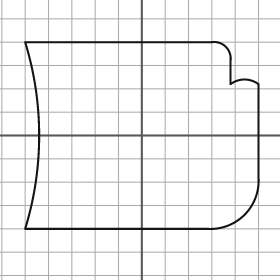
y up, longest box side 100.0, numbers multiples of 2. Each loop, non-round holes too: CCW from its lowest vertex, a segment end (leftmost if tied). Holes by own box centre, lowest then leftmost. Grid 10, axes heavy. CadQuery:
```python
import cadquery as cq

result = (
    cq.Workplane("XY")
    .moveTo(-50.0, -40.0)
    .lineTo(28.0, -40.0)
    .threePointArc((44.0, -34.0), (50.0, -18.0))
    .lineTo(50.0, 22.0)
    .threePointArc((44.0, 24.0), (38.0, 22.0))
    .lineTo(38.0, 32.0)
    .threePointArc((36.0, 38.0), (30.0, 40.0))
    .lineTo(-50.0, 40.0)
    .threePointArc((-44.0, 0.0), (-50.0, -40.0))
    .close()
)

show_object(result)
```